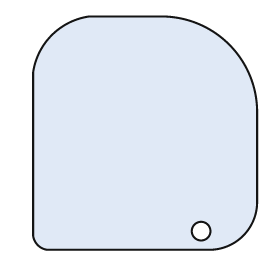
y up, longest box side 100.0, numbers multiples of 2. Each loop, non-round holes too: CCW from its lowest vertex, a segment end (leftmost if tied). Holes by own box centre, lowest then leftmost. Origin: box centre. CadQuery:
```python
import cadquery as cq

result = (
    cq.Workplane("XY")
    .moveTo(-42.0, -50.0)
    .lineTo(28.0, -50.0)
    .threePointArc((42.0, -44.0), (48.0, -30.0))
    .lineTo(48.0, 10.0)
    .threePointArc((36.0, 38.0), (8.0, 50.0))
    .lineTo(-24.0, 50.0)
    .threePointArc((-40.0, 42.0), (-48.0, 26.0))
    .lineTo(-48.0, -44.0)
    .threePointArc((-46.0, -48.0), (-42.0, -50.0))
    .close()
    .moveTo(24.0, -42.0)
    .circle(4.0)
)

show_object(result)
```